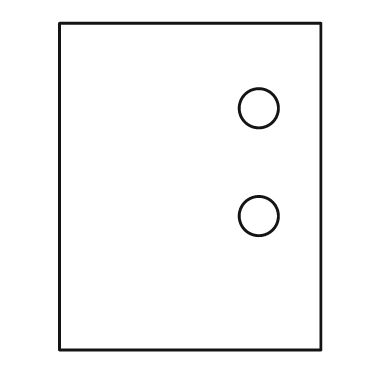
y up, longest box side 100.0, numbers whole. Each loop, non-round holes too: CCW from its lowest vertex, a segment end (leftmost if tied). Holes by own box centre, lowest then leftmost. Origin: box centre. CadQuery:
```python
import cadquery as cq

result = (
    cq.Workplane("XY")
    .moveTo(-40.0, -50.0)
    .lineTo(40.0, -50.0)
    .lineTo(40.0, 50.0)
    .lineTo(-40.0, 50.0)
    .close()
    .moveTo(21.0, -9.0)
    .circle(6.0)
    .moveTo(21.0, 24.0)
    .circle(6.0)
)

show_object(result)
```